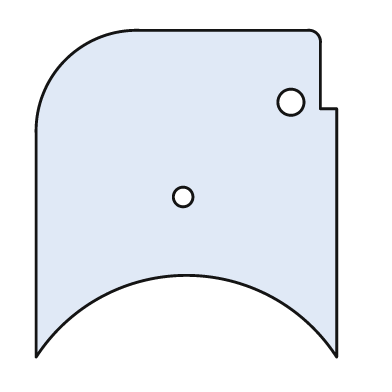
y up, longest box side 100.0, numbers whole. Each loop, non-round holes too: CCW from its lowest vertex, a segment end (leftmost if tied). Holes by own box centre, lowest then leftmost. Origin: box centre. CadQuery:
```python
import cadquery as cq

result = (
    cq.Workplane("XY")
    .moveTo(-46.0, -50.0)
    .threePointArc((0.0, -25.0), (46.0, -50.0))
    .lineTo(46.0, 26.0)
    .lineTo(41.0, 26.0)
    .lineTo(41.0, 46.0)
    .threePointArc((40.0, 49.0), (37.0, 50.0))
    .lineTo(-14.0, 50.0)
    .threePointArc((-37.0, 41.0), (-46.0, 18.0))
    .close()
    .moveTo(-1.0, -1.0)
    .circle(3.0)
    .moveTo(32.0, 28.0)
    .circle(4.0)
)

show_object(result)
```